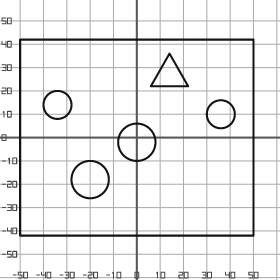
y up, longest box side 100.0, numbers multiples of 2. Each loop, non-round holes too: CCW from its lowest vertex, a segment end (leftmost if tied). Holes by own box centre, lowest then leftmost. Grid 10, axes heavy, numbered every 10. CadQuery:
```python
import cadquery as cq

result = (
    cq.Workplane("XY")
    .moveTo(-50.0, -42.0)
    .lineTo(50.0, -42.0)
    .lineTo(50.0, 42.0)
    .lineTo(-50.0, 42.0)
    .close()
    .moveTo(-20.0, -18.0)
    .circle(8.0)
    .moveTo(0.0, -2.0)
    .circle(8.0)
    .moveTo(36.0, 10.0)
    .circle(6.0)
    .moveTo(-34.0, 14.0)
    .circle(6.0)
    .moveTo(6.0, 22.0)
    .lineTo(22.0, 22.0)
    .lineTo(14.0, 36.0)
    .close()
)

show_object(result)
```